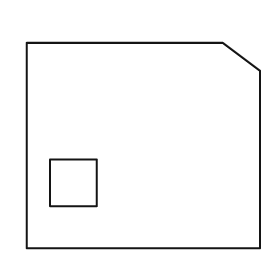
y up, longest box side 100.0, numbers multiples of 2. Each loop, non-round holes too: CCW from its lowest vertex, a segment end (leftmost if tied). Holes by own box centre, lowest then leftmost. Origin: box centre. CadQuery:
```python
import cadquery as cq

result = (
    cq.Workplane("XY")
    .moveTo(-50.0, -44.0)
    .lineTo(50.0, -44.0)
    .lineTo(50.0, 32.0)
    .lineTo(34.0, 44.0)
    .lineTo(-50.0, 44.0)
    .close()
    .moveTo(-40.0, -26.0)
    .lineTo(-20.0, -26.0)
    .lineTo(-20.0, -6.0)
    .lineTo(-40.0, -6.0)
    .close()
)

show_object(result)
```